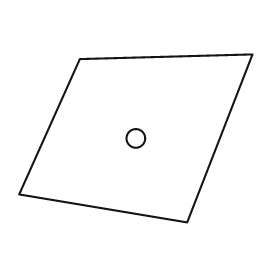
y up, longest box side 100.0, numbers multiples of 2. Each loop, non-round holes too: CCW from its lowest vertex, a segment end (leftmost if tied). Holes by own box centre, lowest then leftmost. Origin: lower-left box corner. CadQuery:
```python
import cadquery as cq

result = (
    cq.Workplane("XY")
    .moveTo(72.0, 0.0)
    .lineTo(100.0, 72.0)
    .lineTo(26.0, 70.0)
    .lineTo(0.0, 12.0)
    .close()
    .moveTo(50.0, 36.0)
    .circle(4.0)
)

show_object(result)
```